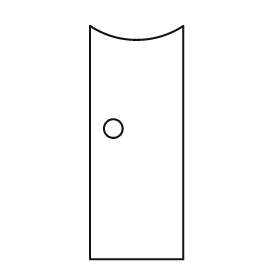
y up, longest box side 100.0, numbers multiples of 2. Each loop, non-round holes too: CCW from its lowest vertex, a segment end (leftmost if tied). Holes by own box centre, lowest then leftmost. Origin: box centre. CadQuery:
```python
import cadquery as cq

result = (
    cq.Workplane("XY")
    .moveTo(-20.0, -50.0)
    .lineTo(20.0, -50.0)
    .lineTo(20.0, 50.0)
    .threePointArc((0.0, 44.0), (-20.0, 50.0))
    .close()
    .moveTo(-10.0, 6.0)
    .circle(4.0)
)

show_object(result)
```